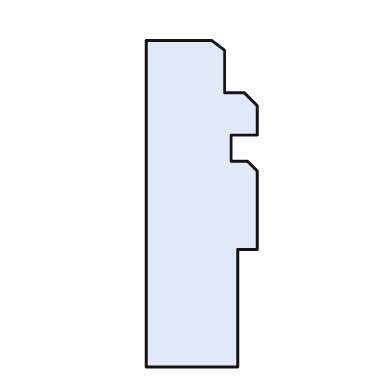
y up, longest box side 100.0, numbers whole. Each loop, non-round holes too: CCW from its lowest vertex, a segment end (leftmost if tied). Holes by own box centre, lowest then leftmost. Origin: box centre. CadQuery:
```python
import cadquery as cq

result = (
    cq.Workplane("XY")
    .moveTo(-17.0, -50.0)
    .lineTo(11.0, -50.0)
    .lineTo(11.0, -14.0)
    .lineTo(17.0, -14.0)
    .lineTo(17.0, 10.0)
    .lineTo(14.0, 13.0)
    .lineTo(9.0, 13.0)
    .lineTo(9.0, 21.0)
    .lineTo(17.0, 21.0)
    .lineTo(17.0, 30.0)
    .lineTo(13.0, 34.0)
    .lineTo(7.0, 34.0)
    .lineTo(7.0, 47.0)
    .lineTo(3.0, 50.0)
    .lineTo(-17.0, 50.0)
    .close()
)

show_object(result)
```